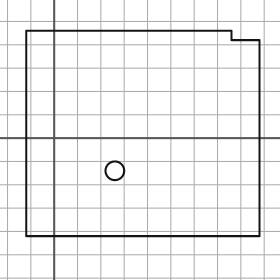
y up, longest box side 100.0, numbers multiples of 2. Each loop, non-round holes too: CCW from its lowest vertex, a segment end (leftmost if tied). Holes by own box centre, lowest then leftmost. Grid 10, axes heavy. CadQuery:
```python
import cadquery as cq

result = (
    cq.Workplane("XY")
    .moveTo(-12.0, -42.0)
    .lineTo(88.0, -42.0)
    .lineTo(88.0, 42.0)
    .lineTo(76.0, 42.0)
    .lineTo(76.0, 46.0)
    .lineTo(-12.0, 46.0)
    .close()
    .moveTo(26.0, -14.0)
    .circle(4.0)
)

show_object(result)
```